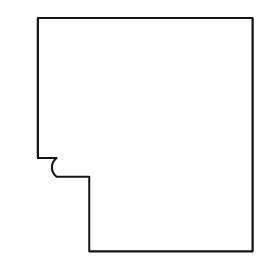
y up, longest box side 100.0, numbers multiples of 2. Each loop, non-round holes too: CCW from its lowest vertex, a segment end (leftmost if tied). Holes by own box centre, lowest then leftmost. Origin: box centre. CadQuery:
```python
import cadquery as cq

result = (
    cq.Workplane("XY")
    .moveTo(-24.0, -50.0)
    .lineTo(46.0, -50.0)
    .lineTo(46.0, 50.0)
    .lineTo(-46.0, 50.0)
    .lineTo(-46.0, -10.0)
    .lineTo(-38.0, -10.0)
    .threePointArc((-40.0, -14.0), (-38.0, -18.0))
    .lineTo(-24.0, -18.0)
    .close()
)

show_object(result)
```